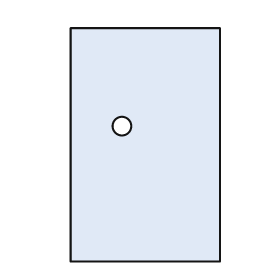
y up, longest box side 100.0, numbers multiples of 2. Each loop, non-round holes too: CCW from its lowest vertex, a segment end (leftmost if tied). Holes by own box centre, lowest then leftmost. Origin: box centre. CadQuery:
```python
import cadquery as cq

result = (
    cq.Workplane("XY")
    .moveTo(-32.0, -50.0)
    .lineTo(32.0, -50.0)
    .lineTo(32.0, 50.0)
    .lineTo(-32.0, 50.0)
    .close()
    .moveTo(-10.0, 8.0)
    .circle(4.0)
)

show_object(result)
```